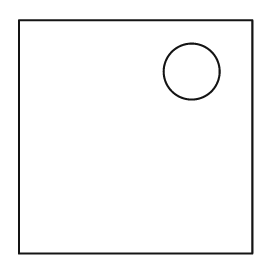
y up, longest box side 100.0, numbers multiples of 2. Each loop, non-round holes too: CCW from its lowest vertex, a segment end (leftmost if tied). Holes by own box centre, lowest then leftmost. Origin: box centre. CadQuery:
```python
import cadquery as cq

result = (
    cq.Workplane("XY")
    .moveTo(-50.0, -50.0)
    .lineTo(50.0, -50.0)
    .lineTo(50.0, 50.0)
    .lineTo(-50.0, 50.0)
    .close()
    .moveTo(24.0, 28.0)
    .circle(12.0)
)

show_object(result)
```